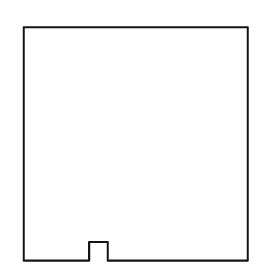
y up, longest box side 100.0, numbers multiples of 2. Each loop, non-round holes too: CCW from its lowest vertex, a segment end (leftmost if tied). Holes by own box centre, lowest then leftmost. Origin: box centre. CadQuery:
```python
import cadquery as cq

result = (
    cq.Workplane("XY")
    .moveTo(-48.0, -50.0)
    .lineTo(-20.0, -50.0)
    .lineTo(-20.0, -42.0)
    .lineTo(-12.0, -42.0)
    .lineTo(-12.0, -50.0)
    .lineTo(48.0, -50.0)
    .lineTo(48.0, 50.0)
    .lineTo(-48.0, 50.0)
    .close()
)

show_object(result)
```